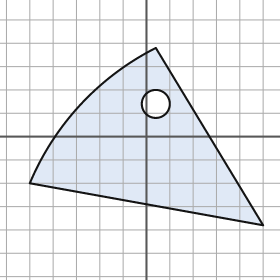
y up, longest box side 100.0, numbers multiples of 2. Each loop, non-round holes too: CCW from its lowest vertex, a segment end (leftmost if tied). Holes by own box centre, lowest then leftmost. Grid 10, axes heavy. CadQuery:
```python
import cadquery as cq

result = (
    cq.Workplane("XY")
    .moveTo(50.0, -38.0)
    .lineTo(4.0, 38.0)
    .threePointArc((-28.0, 14.0), (-50.0, -20.0))
    .close()
    .moveTo(4.0, 14.0)
    .circle(6.0)
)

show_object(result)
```